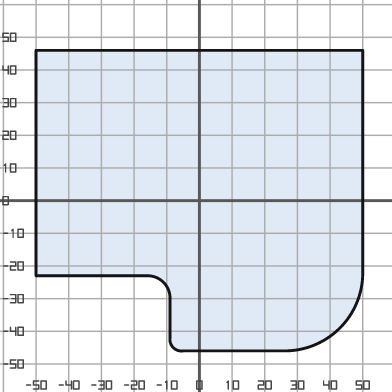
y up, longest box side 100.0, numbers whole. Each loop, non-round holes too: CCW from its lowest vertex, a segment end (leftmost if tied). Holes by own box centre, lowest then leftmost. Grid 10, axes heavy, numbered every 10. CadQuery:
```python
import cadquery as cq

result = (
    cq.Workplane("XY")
    .moveTo(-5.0, -46.0)
    .lineTo(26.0, -46.0)
    .threePointArc((43.0, -39.0), (50.0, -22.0))
    .lineTo(50.0, 46.0)
    .lineTo(-50.0, 46.0)
    .lineTo(-50.0, -23.0)
    .lineTo(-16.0, -23.0)
    .threePointArc((-11.0, -25.0), (-9.0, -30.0))
    .lineTo(-9.0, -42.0)
    .threePointArc((-8.0, -45.0), (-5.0, -46.0))
    .close()
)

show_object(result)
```